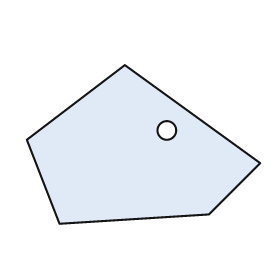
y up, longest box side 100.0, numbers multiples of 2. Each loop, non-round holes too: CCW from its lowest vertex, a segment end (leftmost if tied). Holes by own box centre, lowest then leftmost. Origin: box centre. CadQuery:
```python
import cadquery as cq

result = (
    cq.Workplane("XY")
    .moveTo(-36.0, -34.0)
    .lineTo(28.0, -30.0)
    .lineTo(50.0, -8.0)
    .lineTo(-8.0, 34.0)
    .lineTo(-50.0, 2.0)
    .close()
    .moveTo(10.0, 6.0)
    .circle(4.0)
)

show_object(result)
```